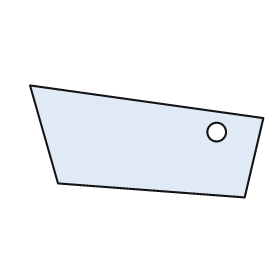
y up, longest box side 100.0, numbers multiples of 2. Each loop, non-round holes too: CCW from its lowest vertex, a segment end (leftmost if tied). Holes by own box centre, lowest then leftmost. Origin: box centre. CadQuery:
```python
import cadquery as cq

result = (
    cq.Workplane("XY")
    .moveTo(42.0, -24.0)
    .lineTo(50.0, 10.0)
    .lineTo(-50.0, 24.0)
    .lineTo(-38.0, -18.0)
    .close()
    .moveTo(30.0, 4.0)
    .circle(4.0)
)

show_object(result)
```